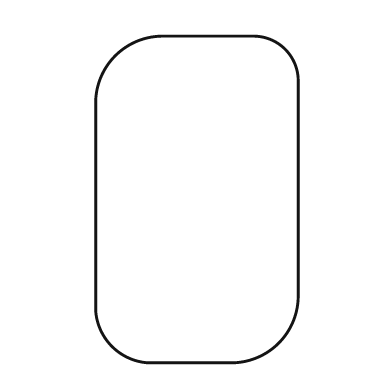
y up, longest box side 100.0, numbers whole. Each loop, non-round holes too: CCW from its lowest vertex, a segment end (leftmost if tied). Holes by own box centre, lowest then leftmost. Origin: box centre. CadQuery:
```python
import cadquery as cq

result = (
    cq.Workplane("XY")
    .moveTo(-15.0, -50.0)
    .lineTo(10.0, -50.0)
    .threePointArc((25.0, -44.0), (31.0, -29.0))
    .lineTo(31.0, 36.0)
    .threePointArc((27.0, 46.0), (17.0, 50.0))
    .lineTo(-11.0, 50.0)
    .threePointArc((-25.0, 44.0), (-31.0, 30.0))
    .lineTo(-31.0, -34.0)
    .threePointArc((-26.0, -45.0), (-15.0, -50.0))
    .close()
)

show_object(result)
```